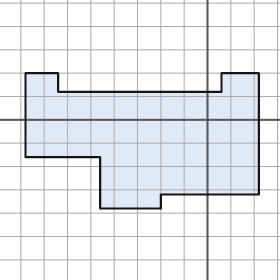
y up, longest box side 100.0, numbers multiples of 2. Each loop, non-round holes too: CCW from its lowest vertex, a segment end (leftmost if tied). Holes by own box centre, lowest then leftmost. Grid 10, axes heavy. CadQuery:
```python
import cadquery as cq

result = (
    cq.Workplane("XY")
    .moveTo(-46.0, -38.0)
    .lineTo(-20.0, -38.0)
    .lineTo(-20.0, -32.0)
    .lineTo(22.0, -32.0)
    .lineTo(22.0, 20.0)
    .lineTo(6.0, 20.0)
    .lineTo(6.0, 12.0)
    .lineTo(-64.0, 12.0)
    .lineTo(-64.0, 20.0)
    .lineTo(-78.0, 20.0)
    .lineTo(-78.0, -16.0)
    .lineTo(-46.0, -16.0)
    .close()
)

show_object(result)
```